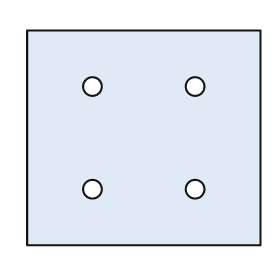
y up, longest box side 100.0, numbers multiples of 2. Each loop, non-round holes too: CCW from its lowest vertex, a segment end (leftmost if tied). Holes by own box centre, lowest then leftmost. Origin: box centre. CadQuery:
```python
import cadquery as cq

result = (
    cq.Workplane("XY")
    .moveTo(-50.0, -46.0)
    .lineTo(50.0, -46.0)
    .lineTo(50.0, 46.0)
    .lineTo(-50.0, 46.0)
    .close()
    .moveTo(-22.0, -22.0)
    .circle(4.0)
    .moveTo(22.0, -22.0)
    .circle(4.0)
    .moveTo(-22.0, 22.0)
    .circle(4.0)
    .moveTo(22.0, 22.0)
    .circle(4.0)
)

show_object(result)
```